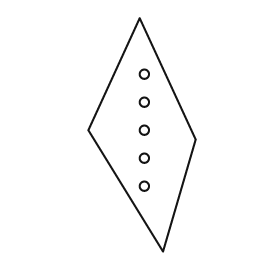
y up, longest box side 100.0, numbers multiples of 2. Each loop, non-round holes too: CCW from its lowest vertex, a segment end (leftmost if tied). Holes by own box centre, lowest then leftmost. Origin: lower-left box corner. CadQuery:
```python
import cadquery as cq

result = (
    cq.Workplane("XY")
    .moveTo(32.0, 0.0)
    .lineTo(46.0, 48.0)
    .lineTo(22.0, 100.0)
    .lineTo(0.0, 52.0)
    .close()
    .moveTo(24.0, 28.0)
    .circle(2.0)
    .moveTo(24.0, 40.0)
    .circle(2.0)
    .moveTo(24.0, 52.0)
    .circle(2.0)
    .moveTo(24.0, 64.0)
    .circle(2.0)
    .moveTo(24.0, 76.0)
    .circle(2.0)
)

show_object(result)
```